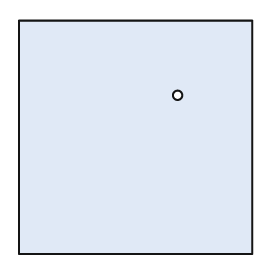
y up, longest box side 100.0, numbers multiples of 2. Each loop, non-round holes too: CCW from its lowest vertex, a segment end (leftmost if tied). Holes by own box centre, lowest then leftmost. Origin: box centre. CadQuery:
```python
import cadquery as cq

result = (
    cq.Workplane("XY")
    .moveTo(-50.0, -50.0)
    .lineTo(50.0, -50.0)
    .lineTo(50.0, 50.0)
    .lineTo(-50.0, 50.0)
    .close()
    .moveTo(18.0, 18.0)
    .circle(2.0)
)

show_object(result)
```